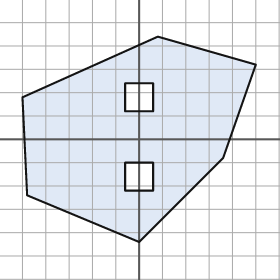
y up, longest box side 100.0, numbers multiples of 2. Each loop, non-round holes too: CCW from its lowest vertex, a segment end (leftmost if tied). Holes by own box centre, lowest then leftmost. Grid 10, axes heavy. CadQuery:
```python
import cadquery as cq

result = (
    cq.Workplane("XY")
    .moveTo(0.0, -44.0)
    .lineTo(36.0, -8.0)
    .lineTo(50.0, 32.0)
    .lineTo(8.0, 44.0)
    .lineTo(-50.0, 18.0)
    .lineTo(-48.0, -24.0)
    .close()
    .moveTo(-6.0, -22.0)
    .lineTo(6.0, -22.0)
    .lineTo(6.0, -10.0)
    .lineTo(-6.0, -10.0)
    .close()
    .moveTo(-6.0, 12.0)
    .lineTo(6.0, 12.0)
    .lineTo(6.0, 24.0)
    .lineTo(-6.0, 24.0)
    .close()
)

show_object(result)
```